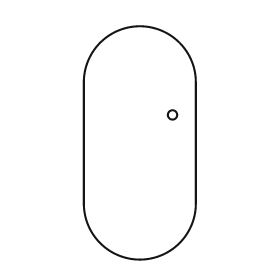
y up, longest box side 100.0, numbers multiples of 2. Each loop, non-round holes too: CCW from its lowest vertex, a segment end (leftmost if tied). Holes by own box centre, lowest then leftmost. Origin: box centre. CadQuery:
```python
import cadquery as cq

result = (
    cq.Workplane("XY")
    .moveTo(-24.0, -26.0)
    .threePointArc((0.0, -50.0), (24.0, -26.0))
    .lineTo(24.0, 26.0)
    .threePointArc((0.0, 50.0), (-24.0, 26.0))
    .close()
    .moveTo(14.0, 12.0)
    .circle(2.0)
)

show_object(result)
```